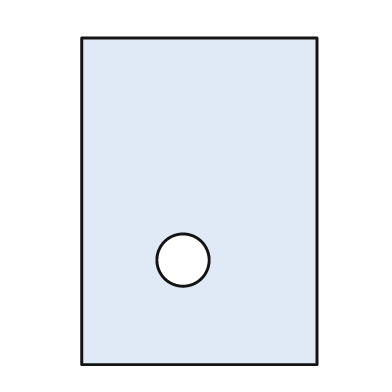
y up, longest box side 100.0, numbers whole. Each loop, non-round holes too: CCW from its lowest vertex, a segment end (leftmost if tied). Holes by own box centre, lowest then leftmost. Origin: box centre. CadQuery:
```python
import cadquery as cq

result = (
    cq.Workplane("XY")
    .moveTo(-36.0, -50.0)
    .lineTo(36.0, -50.0)
    .lineTo(36.0, 50.0)
    .lineTo(-36.0, 50.0)
    .close()
    .moveTo(-5.0, -18.0)
    .circle(8.0)
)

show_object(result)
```